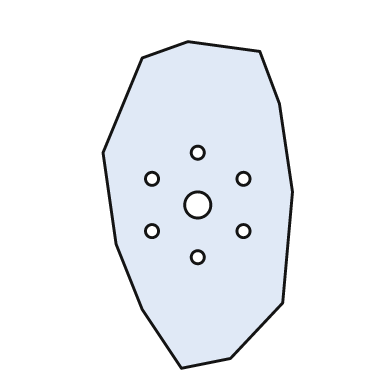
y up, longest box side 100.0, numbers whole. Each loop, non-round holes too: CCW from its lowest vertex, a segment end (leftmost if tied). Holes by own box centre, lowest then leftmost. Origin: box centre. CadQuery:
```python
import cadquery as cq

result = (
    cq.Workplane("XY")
    .moveTo(-5.0, -50.0)
    .lineTo(10.0, -47.0)
    .lineTo(26.0, -30.0)
    .lineTo(29.0, 4.0)
    .lineTo(25.0, 31.0)
    .lineTo(19.0, 47.0)
    .lineTo(-3.0, 50.0)
    .lineTo(-17.0, 45.0)
    .lineTo(-29.0, 16.0)
    .lineTo(-25.0, -12.0)
    .lineTo(-17.0, -32.0)
    .close()
    .moveTo(0.0, -16.0)
    .circle(2.0)
    .moveTo(-14.0, -8.0)
    .circle(2.0)
    .moveTo(14.0, -8.0)
    .circle(2.0)
    .moveTo(0.0, 0.0)
    .circle(4.0)
    .moveTo(-14.0, 8.0)
    .circle(2.0)
    .moveTo(14.0, 8.0)
    .circle(2.0)
    .moveTo(0.0, 16.0)
    .circle(2.0)
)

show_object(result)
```